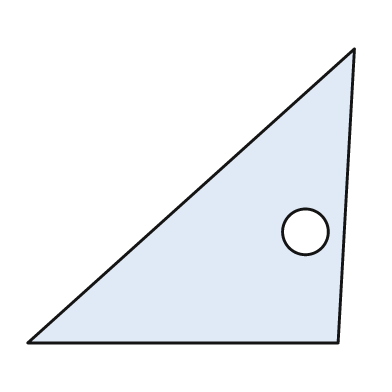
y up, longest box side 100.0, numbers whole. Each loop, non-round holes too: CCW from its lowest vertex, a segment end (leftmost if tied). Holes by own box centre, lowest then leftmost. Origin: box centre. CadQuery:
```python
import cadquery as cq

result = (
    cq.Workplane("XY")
    .moveTo(-50.0, -45.0)
    .lineTo(45.0, -45.0)
    .lineTo(50.0, 45.0)
    .close()
    .moveTo(35.0, -11.0)
    .circle(7.0)
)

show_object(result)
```